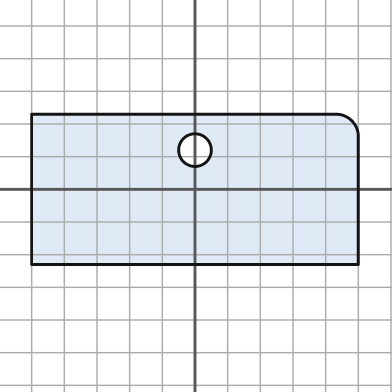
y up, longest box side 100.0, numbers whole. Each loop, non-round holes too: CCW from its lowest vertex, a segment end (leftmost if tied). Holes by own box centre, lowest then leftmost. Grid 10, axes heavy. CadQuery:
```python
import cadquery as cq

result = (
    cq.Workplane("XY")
    .moveTo(-50.0, -23.0)
    .lineTo(50.0, -23.0)
    .lineTo(50.0, 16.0)
    .threePointArc((48.0, 21.0), (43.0, 23.0))
    .lineTo(-50.0, 23.0)
    .close()
    .moveTo(0.0, 12.0)
    .circle(5.0)
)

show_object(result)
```